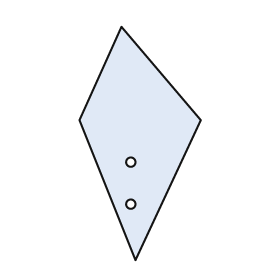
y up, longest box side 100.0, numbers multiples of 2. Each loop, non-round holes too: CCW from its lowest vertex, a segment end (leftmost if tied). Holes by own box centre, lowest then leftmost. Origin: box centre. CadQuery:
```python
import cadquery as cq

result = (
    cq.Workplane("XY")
    .moveTo(-2.0, -50.0)
    .lineTo(26.0, 10.0)
    .lineTo(-8.0, 50.0)
    .lineTo(-26.0, 10.0)
    .close()
    .moveTo(-4.0, -26.0)
    .circle(2.0)
    .moveTo(-4.0, -8.0)
    .circle(2.0)
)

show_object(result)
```